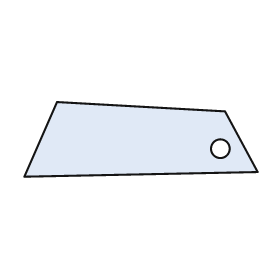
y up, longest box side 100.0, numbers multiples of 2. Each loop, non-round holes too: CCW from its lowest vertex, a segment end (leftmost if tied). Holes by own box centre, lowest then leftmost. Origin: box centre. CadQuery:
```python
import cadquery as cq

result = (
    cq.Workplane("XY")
    .moveTo(-50.0, -16.0)
    .lineTo(50.0, -14.0)
    .lineTo(36.0, 12.0)
    .lineTo(-36.0, 16.0)
    .close()
    .moveTo(34.0, -4.0)
    .circle(4.0)
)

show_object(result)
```